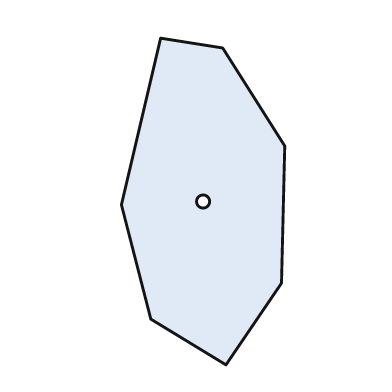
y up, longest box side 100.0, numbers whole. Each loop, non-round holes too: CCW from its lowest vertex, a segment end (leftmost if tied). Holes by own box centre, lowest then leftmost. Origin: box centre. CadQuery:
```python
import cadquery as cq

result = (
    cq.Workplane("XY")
    .moveTo(7.0, -50.0)
    .lineTo(24.0, -25.0)
    .lineTo(25.0, 17.0)
    .lineTo(6.0, 47.0)
    .lineTo(-13.0, 50.0)
    .lineTo(-25.0, -1.0)
    .lineTo(-16.0, -36.0)
    .close()
    .moveTo(0.0, 0.0)
    .circle(2.0)
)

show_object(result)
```